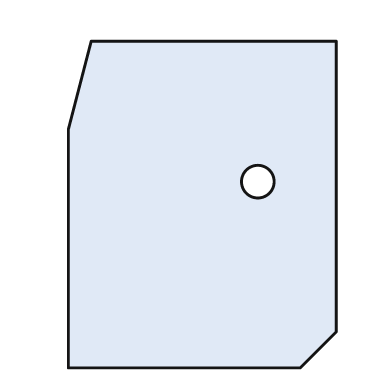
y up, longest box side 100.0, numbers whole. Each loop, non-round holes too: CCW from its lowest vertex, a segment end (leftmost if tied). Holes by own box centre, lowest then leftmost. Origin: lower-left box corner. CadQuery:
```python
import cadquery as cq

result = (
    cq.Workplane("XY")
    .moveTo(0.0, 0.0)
    .lineTo(71.0, 0.0)
    .lineTo(82.0, 11.0)
    .lineTo(82.0, 100.0)
    .lineTo(7.0, 100.0)
    .lineTo(0.0, 73.0)
    .close()
    .moveTo(58.0, 57.0)
    .circle(5.0)
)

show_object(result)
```